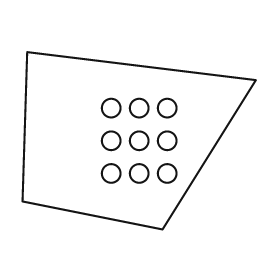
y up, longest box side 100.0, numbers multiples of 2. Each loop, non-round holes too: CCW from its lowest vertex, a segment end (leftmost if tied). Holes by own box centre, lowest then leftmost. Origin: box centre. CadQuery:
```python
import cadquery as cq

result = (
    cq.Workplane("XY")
    .moveTo(10.0, -38.0)
    .lineTo(50.0, 26.0)
    .lineTo(-48.0, 38.0)
    .lineTo(-50.0, -26.0)
    .close()
    .moveTo(-12.0, -14.0)
    .circle(4.0)
    .moveTo(0.0, -14.0)
    .circle(4.0)
    .moveTo(12.0, -14.0)
    .circle(4.0)
    .moveTo(-12.0, 0.0)
    .circle(4.0)
    .moveTo(0.0, 0.0)
    .circle(4.0)
    .moveTo(12.0, 0.0)
    .circle(4.0)
    .moveTo(-12.0, 14.0)
    .circle(4.0)
    .moveTo(0.0, 14.0)
    .circle(4.0)
    .moveTo(12.0, 14.0)
    .circle(4.0)
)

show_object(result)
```